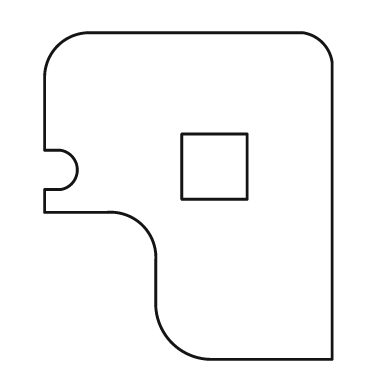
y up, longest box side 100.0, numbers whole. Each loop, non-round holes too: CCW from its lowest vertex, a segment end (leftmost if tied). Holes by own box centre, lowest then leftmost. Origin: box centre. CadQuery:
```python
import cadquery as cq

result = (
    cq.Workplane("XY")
    .moveTo(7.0, -50.0)
    .lineTo(44.0, -50.0)
    .lineTo(44.0, 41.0)
    .threePointArc((41.0, 47.0), (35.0, 50.0))
    .lineTo(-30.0, 50.0)
    .threePointArc((-40.0, 46.0), (-44.0, 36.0))
    .lineTo(-44.0, 14.0)
    .lineTo(-39.0, 14.0)
    .threePointArc((-34.0, 8.0), (-39.0, 2.0))
    .lineTo(-44.0, 2.0)
    .lineTo(-44.0, -5.0)
    .lineTo(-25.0, -5.0)
    .threePointArc((-14.0, -9.0), (-10.0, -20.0))
    .lineTo(-10.0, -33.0)
    .threePointArc((-5.0, -45.0), (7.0, -50.0))
    .close()
    .moveTo(-2.0, -1.0)
    .lineTo(18.0, -1.0)
    .lineTo(18.0, 19.0)
    .lineTo(-2.0, 19.0)
    .close()
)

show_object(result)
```